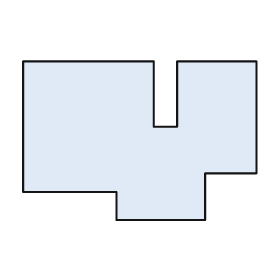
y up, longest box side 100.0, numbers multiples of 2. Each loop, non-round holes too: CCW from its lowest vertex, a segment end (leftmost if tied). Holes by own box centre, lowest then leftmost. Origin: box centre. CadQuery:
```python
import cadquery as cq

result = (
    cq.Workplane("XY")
    .moveTo(-10.0, -34.0)
    .lineTo(28.0, -34.0)
    .lineTo(28.0, -14.0)
    .lineTo(50.0, -14.0)
    .lineTo(50.0, 34.0)
    .lineTo(16.0, 34.0)
    .lineTo(16.0, 6.0)
    .lineTo(6.0, 6.0)
    .lineTo(6.0, 34.0)
    .lineTo(-50.0, 34.0)
    .lineTo(-50.0, -22.0)
    .lineTo(-10.0, -22.0)
    .close()
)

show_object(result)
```